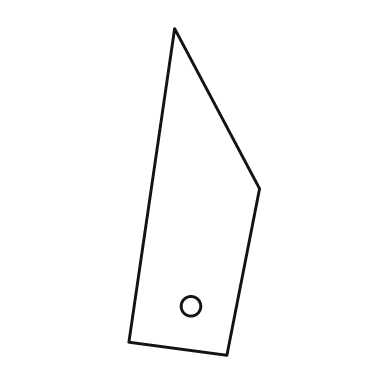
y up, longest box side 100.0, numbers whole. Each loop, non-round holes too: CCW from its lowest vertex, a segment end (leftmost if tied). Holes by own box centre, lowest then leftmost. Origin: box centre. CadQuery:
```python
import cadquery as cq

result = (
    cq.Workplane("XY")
    .moveTo(10.0, -50.0)
    .lineTo(20.0, 1.0)
    .lineTo(-6.0, 50.0)
    .lineTo(-20.0, -46.0)
    .close()
    .moveTo(-1.0, -35.0)
    .circle(3.0)
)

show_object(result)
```